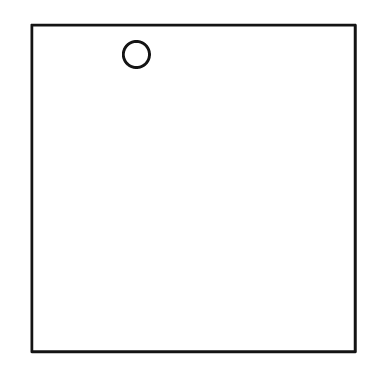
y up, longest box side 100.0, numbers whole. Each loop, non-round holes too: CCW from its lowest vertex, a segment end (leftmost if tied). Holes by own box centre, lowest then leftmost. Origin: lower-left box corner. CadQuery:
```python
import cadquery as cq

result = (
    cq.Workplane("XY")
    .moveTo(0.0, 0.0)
    .lineTo(99.0, 0.0)
    .lineTo(99.0, 100.0)
    .lineTo(0.0, 100.0)
    .close()
    .moveTo(32.0, 91.0)
    .circle(4.0)
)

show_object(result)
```